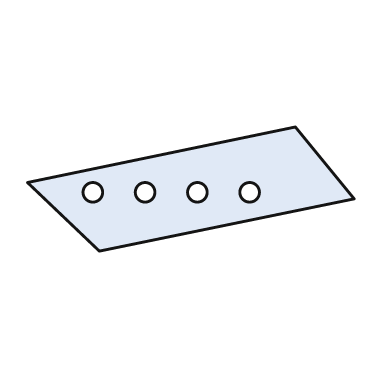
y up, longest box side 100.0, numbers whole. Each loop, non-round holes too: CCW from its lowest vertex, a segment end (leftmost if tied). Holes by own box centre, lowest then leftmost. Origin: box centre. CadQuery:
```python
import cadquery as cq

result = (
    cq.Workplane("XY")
    .moveTo(-28.0, -19.0)
    .lineTo(50.0, -3.0)
    .lineTo(32.0, 19.0)
    .lineTo(-50.0, 2.0)
    .close()
    .moveTo(-30.0, -1.0)
    .circle(3.0)
    .moveTo(-14.0, -1.0)
    .circle(3.0)
    .moveTo(2.0, -1.0)
    .circle(3.0)
    .moveTo(18.0, -1.0)
    .circle(3.0)
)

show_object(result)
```